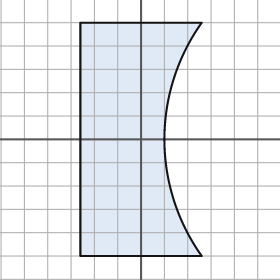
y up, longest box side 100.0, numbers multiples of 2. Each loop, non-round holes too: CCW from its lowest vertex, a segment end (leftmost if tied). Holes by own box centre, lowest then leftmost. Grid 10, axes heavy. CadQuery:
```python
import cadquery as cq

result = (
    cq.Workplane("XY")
    .moveTo(-26.0, -50.0)
    .lineTo(26.0, -50.0)
    .threePointArc((10.0, 0.0), (26.0, 50.0))
    .lineTo(-26.0, 50.0)
    .close()
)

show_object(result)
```